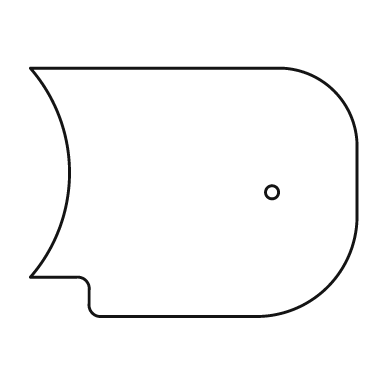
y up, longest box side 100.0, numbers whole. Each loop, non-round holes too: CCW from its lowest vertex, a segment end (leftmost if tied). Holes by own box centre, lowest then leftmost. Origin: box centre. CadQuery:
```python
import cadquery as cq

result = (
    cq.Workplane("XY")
    .moveTo(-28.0, -38.0)
    .lineTo(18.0, -38.0)
    .threePointArc((41.0, -29.0), (50.0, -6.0))
    .lineTo(50.0, 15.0)
    .threePointArc((43.0, 31.0), (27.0, 38.0))
    .lineTo(-50.0, 38.0)
    .threePointArc((-38.0, 6.0), (-50.0, -26.0))
    .lineTo(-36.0, -26.0)
    .threePointArc((-33.0, -27.0), (-32.0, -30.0))
    .lineTo(-32.0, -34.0)
    .threePointArc((-31.0, -37.0), (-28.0, -38.0))
    .close()
    .moveTo(24.0, 0.0)
    .circle(2.0)
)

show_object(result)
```